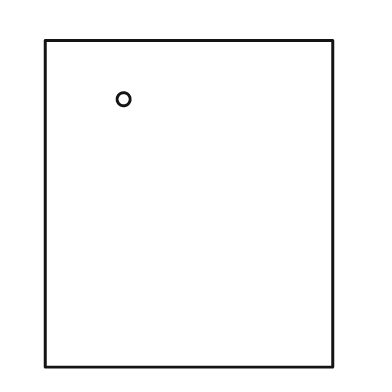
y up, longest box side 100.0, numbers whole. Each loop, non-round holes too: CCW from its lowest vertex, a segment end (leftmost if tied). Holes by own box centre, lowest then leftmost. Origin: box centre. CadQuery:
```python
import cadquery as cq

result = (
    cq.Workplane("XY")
    .moveTo(-44.0, -50.0)
    .lineTo(44.0, -50.0)
    .lineTo(44.0, 50.0)
    .lineTo(-44.0, 50.0)
    .close()
    .moveTo(-20.0, 32.0)
    .circle(2.0)
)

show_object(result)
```